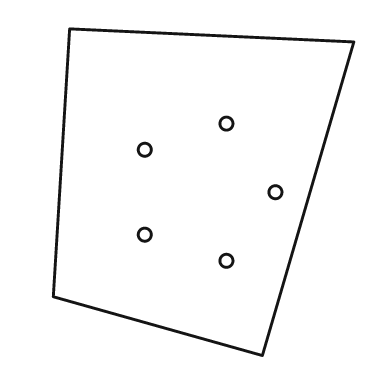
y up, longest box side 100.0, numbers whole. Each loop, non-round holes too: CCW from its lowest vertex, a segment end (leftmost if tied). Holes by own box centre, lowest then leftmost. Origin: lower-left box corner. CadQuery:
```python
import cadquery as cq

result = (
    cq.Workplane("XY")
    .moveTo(64.0, 0.0)
    .lineTo(92.0, 96.0)
    .lineTo(5.0, 100.0)
    .lineTo(0.0, 18.0)
    .close()
    .moveTo(53.0, 29.0)
    .circle(2.0)
    .moveTo(28.0, 37.0)
    .circle(2.0)
    .moveTo(68.0, 50.0)
    .circle(2.0)
    .moveTo(28.0, 63.0)
    .circle(2.0)
    .moveTo(53.0, 71.0)
    .circle(2.0)
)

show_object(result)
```